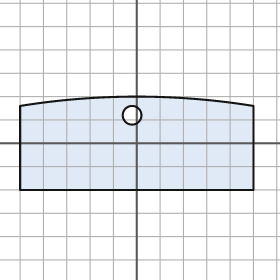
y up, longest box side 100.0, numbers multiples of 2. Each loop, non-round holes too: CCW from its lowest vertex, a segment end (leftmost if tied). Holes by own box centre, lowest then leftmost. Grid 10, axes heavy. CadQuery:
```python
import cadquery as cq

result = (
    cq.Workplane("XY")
    .moveTo(-50.0, -20.0)
    .lineTo(50.0, -20.0)
    .lineTo(50.0, 16.0)
    .threePointArc((0.0, 20.0), (-50.0, 16.0))
    .close()
    .moveTo(-2.0, 12.0)
    .circle(4.0)
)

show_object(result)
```